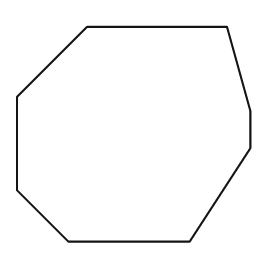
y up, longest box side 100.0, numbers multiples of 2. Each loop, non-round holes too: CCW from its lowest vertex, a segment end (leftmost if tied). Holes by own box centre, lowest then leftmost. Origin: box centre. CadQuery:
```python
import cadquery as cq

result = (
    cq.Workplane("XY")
    .moveTo(-28.0, -46.0)
    .lineTo(24.0, -46.0)
    .lineTo(50.0, -6.0)
    .lineTo(50.0, 10.0)
    .lineTo(40.0, 46.0)
    .lineTo(-20.0, 46.0)
    .lineTo(-50.0, 16.0)
    .lineTo(-50.0, -24.0)
    .close()
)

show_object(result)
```